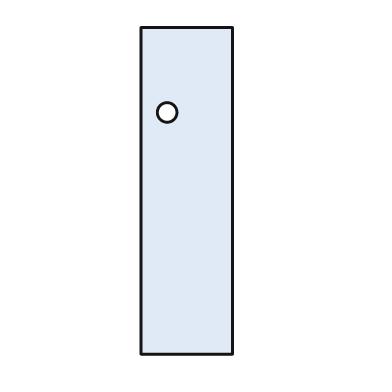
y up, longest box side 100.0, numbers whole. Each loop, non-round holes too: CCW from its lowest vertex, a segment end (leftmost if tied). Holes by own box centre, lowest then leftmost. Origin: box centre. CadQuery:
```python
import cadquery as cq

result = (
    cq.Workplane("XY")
    .moveTo(-14.0, -50.0)
    .lineTo(14.0, -50.0)
    .lineTo(14.0, 50.0)
    .lineTo(-14.0, 50.0)
    .close()
    .moveTo(-6.0, 24.0)
    .circle(3.0)
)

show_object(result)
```